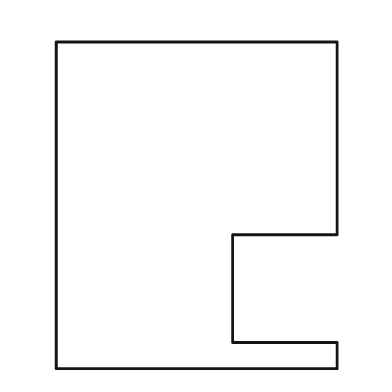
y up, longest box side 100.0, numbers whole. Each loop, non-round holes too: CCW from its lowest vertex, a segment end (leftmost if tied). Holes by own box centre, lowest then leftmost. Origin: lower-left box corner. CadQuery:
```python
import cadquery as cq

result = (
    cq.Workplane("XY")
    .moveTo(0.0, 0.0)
    .lineTo(86.0, 0.0)
    .lineTo(86.0, 8.0)
    .lineTo(54.0, 8.0)
    .lineTo(54.0, 41.0)
    .lineTo(86.0, 41.0)
    .lineTo(86.0, 100.0)
    .lineTo(0.0, 100.0)
    .close()
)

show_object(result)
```